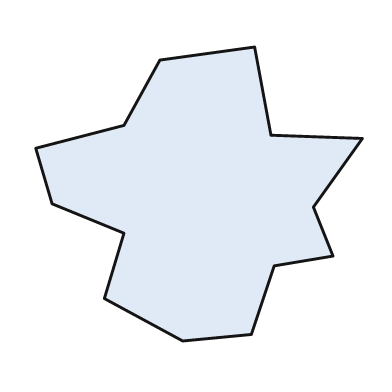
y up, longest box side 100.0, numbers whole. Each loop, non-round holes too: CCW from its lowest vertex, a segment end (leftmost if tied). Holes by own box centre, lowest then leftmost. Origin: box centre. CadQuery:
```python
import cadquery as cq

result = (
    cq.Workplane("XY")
    .moveTo(-5.0, -45.0)
    .lineTo(16.0, -43.0)
    .lineTo(23.0, -22.0)
    .lineTo(41.0, -19.0)
    .lineTo(35.0, -4.0)
    .lineTo(50.0, 17.0)
    .lineTo(22.0, 18.0)
    .lineTo(17.0, 45.0)
    .lineTo(-12.0, 41.0)
    .lineTo(-23.0, 21.0)
    .lineTo(-50.0, 14.0)
    .lineTo(-45.0, -3.0)
    .lineTo(-23.0, -12.0)
    .lineTo(-29.0, -32.0)
    .close()
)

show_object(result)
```